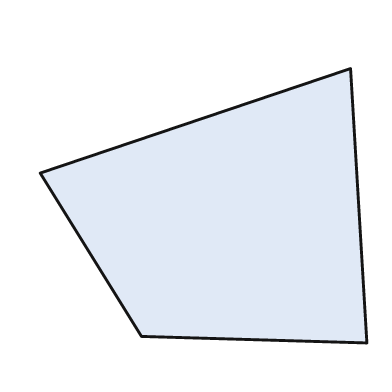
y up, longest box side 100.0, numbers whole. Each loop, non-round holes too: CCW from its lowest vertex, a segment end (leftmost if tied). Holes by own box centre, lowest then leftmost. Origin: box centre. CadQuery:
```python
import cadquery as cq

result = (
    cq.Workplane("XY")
    .moveTo(50.0, -42.0)
    .lineTo(45.0, 42.0)
    .lineTo(-50.0, 10.0)
    .lineTo(-19.0, -40.0)
    .close()
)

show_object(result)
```